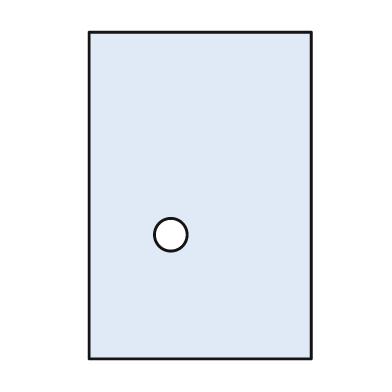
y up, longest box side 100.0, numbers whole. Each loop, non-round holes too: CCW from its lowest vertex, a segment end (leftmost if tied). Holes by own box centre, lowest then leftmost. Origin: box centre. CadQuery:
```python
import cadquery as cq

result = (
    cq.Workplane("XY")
    .moveTo(-34.0, -50.0)
    .lineTo(34.0, -50.0)
    .lineTo(34.0, 50.0)
    .lineTo(-34.0, 50.0)
    .close()
    .moveTo(-9.0, -12.0)
    .circle(5.0)
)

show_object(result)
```